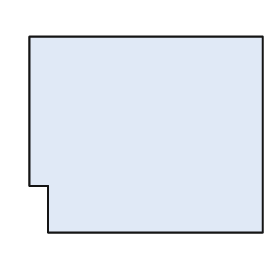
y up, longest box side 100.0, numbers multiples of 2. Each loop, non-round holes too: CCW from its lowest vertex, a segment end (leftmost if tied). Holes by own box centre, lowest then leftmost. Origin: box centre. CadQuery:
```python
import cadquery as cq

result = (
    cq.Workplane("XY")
    .moveTo(-42.0, -42.0)
    .lineTo(50.0, -42.0)
    .lineTo(50.0, 42.0)
    .lineTo(-50.0, 42.0)
    .lineTo(-50.0, -22.0)
    .lineTo(-42.0, -22.0)
    .close()
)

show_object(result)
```